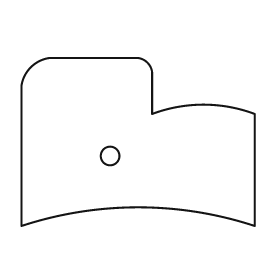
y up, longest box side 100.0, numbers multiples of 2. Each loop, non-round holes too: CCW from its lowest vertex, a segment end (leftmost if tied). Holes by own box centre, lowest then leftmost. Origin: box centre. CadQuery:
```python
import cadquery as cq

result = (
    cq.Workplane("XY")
    .moveTo(-50.0, -36.0)
    .threePointArc((0.0, -28.0), (50.0, -36.0))
    .lineTo(50.0, 12.0)
    .threePointArc((28.0, 16.0), (6.0, 12.0))
    .lineTo(6.0, 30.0)
    .threePointArc((4.0, 34.0), (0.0, 36.0))
    .lineTo(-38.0, 36.0)
    .threePointArc((-46.0, 32.0), (-50.0, 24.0))
    .close()
    .moveTo(-12.0, -6.0)
    .circle(4.0)
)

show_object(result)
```